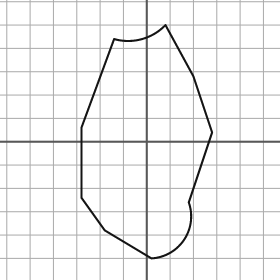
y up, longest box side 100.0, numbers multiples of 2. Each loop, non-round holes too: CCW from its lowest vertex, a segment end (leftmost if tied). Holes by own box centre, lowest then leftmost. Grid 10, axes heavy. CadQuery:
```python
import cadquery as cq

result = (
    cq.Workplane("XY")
    .moveTo(2.0, -50.0)
    .threePointArc((16.0, -42.0), (18.0, -26.0))
    .lineTo(28.0, 4.0)
    .lineTo(20.0, 28.0)
    .lineTo(8.0, 50.0)
    .threePointArc((-2.0, 44.0), (-14.0, 44.0))
    .lineTo(-28.0, 6.0)
    .lineTo(-28.0, -24.0)
    .lineTo(-18.0, -38.0)
    .close()
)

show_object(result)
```